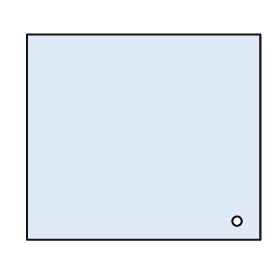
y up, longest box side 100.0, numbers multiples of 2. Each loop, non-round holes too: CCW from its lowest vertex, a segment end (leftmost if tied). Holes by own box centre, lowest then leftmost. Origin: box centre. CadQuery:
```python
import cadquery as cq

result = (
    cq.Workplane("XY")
    .moveTo(-50.0, -44.0)
    .lineTo(50.0, -44.0)
    .lineTo(50.0, 44.0)
    .lineTo(-50.0, 44.0)
    .close()
    .moveTo(40.0, -36.0)
    .circle(2.0)
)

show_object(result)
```